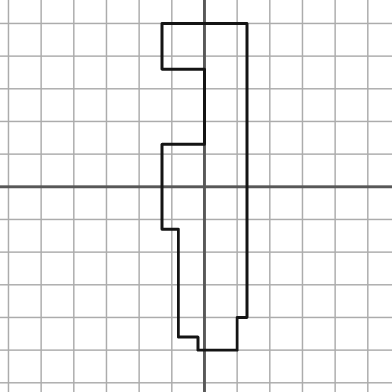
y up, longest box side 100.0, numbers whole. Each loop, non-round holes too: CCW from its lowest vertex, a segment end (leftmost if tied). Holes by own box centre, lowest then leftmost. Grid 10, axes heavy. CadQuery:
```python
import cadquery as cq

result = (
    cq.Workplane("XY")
    .moveTo(-2.0, -50.0)
    .lineTo(10.0, -50.0)
    .lineTo(10.0, -40.0)
    .lineTo(13.0, -40.0)
    .lineTo(13.0, 50.0)
    .lineTo(-13.0, 50.0)
    .lineTo(-13.0, 36.0)
    .lineTo(0.0, 36.0)
    .lineTo(0.0, 13.0)
    .lineTo(-13.0, 13.0)
    .lineTo(-13.0, -13.0)
    .lineTo(-8.0, -13.0)
    .lineTo(-8.0, -46.0)
    .lineTo(-2.0, -46.0)
    .close()
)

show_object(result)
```